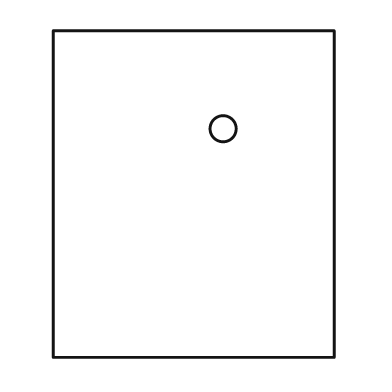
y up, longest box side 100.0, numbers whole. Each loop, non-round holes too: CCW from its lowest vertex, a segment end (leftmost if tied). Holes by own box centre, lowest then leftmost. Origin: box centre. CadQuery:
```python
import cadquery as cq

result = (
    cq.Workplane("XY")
    .moveTo(-43.0, -50.0)
    .lineTo(43.0, -50.0)
    .lineTo(43.0, 50.0)
    .lineTo(-43.0, 50.0)
    .close()
    .moveTo(9.0, 20.0)
    .circle(4.0)
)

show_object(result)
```